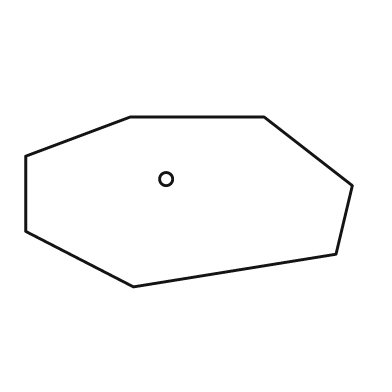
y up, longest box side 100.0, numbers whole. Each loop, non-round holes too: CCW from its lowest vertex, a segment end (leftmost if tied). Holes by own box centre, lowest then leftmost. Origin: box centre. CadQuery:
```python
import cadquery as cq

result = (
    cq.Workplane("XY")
    .moveTo(-17.0, -26.0)
    .lineTo(45.0, -16.0)
    .lineTo(50.0, 5.0)
    .lineTo(23.0, 26.0)
    .lineTo(-18.0, 26.0)
    .lineTo(-50.0, 14.0)
    .lineTo(-50.0, -9.0)
    .close()
    .moveTo(-7.0, 7.0)
    .circle(2.0)
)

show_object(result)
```